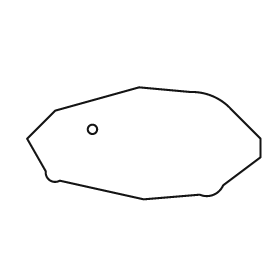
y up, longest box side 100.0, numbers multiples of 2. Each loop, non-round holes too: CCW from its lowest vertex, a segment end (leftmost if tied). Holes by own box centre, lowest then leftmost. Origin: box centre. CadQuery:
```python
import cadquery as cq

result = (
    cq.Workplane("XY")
    .moveTo(0.0, -24.0)
    .lineTo(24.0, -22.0)
    .threePointArc((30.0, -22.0), (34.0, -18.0))
    .lineTo(50.0, -6.0)
    .lineTo(50.0, 2.0)
    .lineTo(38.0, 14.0)
    .threePointArc((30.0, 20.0), (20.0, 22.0))
    .lineTo(-2.0, 24.0)
    .lineTo(-38.0, 14.0)
    .lineTo(-50.0, 2.0)
    .lineTo(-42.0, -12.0)
    .threePointArc((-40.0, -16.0), (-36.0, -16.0))
    .close()
    .moveTo(-22.0, 6.0)
    .circle(2.0)
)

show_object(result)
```